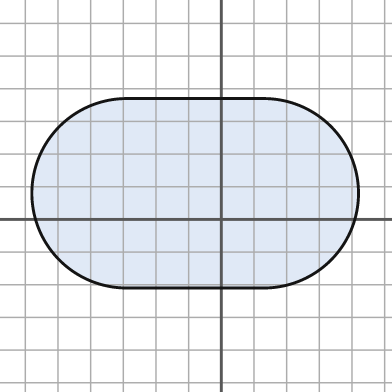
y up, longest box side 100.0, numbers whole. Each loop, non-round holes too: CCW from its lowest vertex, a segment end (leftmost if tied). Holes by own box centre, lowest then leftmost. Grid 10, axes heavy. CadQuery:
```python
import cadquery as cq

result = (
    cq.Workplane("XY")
    .moveTo(-29.0, -21.0)
    .lineTo(13.0, -21.0)
    .threePointArc((42.0, 8.0), (13.0, 37.0))
    .lineTo(-29.0, 37.0)
    .threePointArc((-58.0, 8.0), (-29.0, -21.0))
    .close()
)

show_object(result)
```